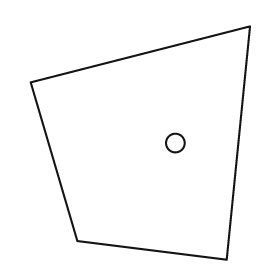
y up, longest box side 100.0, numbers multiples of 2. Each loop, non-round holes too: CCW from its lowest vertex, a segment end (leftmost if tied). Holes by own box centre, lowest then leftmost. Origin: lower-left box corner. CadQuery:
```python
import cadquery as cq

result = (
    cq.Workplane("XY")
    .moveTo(84.0, 0.0)
    .lineTo(94.0, 100.0)
    .lineTo(0.0, 76.0)
    .lineTo(20.0, 8.0)
    .close()
    .moveTo(62.0, 50.0)
    .circle(4.0)
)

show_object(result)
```